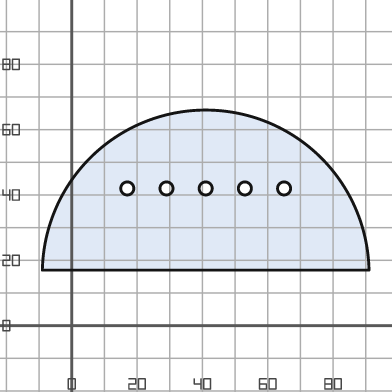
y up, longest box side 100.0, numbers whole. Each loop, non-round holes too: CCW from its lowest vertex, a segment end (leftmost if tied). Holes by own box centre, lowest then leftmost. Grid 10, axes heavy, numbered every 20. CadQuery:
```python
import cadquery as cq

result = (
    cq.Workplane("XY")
    .moveTo(-9.0, 17.0)
    .lineTo(91.0, 17.0)
    .threePointArc((41.0, 66.0), (-9.0, 17.0))
    .close()
    .moveTo(17.0, 42.0)
    .circle(2.0)
    .moveTo(29.0, 42.0)
    .circle(2.0)
    .moveTo(41.0, 42.0)
    .circle(2.0)
    .moveTo(53.0, 42.0)
    .circle(2.0)
    .moveTo(65.0, 42.0)
    .circle(2.0)
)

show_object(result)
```